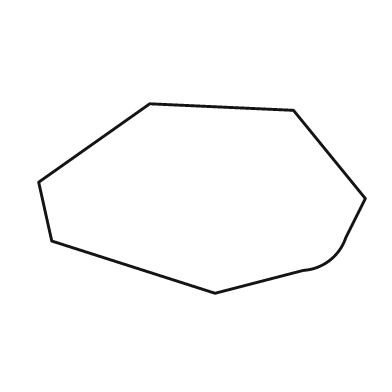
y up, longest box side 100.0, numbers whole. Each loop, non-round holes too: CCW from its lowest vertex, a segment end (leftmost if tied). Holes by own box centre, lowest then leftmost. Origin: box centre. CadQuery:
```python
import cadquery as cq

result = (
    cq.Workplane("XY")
    .moveTo(4.0, -29.0)
    .lineTo(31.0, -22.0)
    .threePointArc((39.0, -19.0), (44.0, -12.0))
    .lineTo(50.0, 0.0)
    .lineTo(28.0, 27.0)
    .lineTo(-16.0, 29.0)
    .lineTo(-50.0, 5.0)
    .lineTo(-46.0, -13.0)
    .close()
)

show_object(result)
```